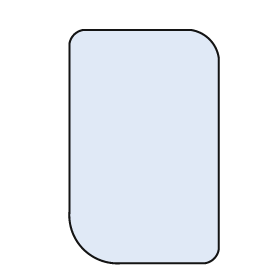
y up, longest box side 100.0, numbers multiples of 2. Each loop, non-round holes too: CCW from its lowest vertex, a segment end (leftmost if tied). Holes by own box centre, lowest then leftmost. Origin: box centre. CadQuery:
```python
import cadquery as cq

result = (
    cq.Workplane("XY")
    .moveTo(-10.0, -50.0)
    .lineTo(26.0, -50.0)
    .threePointArc((30.0, -48.0), (32.0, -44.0))
    .lineTo(32.0, 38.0)
    .threePointArc((28.0, 46.0), (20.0, 50.0))
    .lineTo(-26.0, 50.0)
    .threePointArc((-30.0, 48.0), (-32.0, 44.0))
    .lineTo(-32.0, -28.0)
    .threePointArc((-26.0, -44.0), (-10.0, -50.0))
    .close()
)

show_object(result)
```